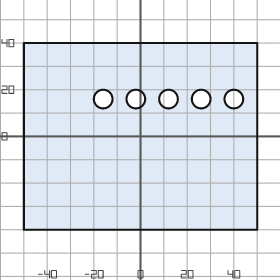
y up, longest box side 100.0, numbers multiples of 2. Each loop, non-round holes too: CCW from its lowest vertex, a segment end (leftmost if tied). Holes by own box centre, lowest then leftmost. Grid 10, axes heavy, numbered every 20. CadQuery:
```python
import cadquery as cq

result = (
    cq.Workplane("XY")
    .moveTo(-50.0, -40.0)
    .lineTo(50.0, -40.0)
    .lineTo(50.0, 40.0)
    .lineTo(-50.0, 40.0)
    .close()
    .moveTo(-16.0, 16.0)
    .circle(4.0)
    .moveTo(-2.0, 16.0)
    .circle(4.0)
    .moveTo(12.0, 16.0)
    .circle(4.0)
    .moveTo(26.0, 16.0)
    .circle(4.0)
    .moveTo(40.0, 16.0)
    .circle(4.0)
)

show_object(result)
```